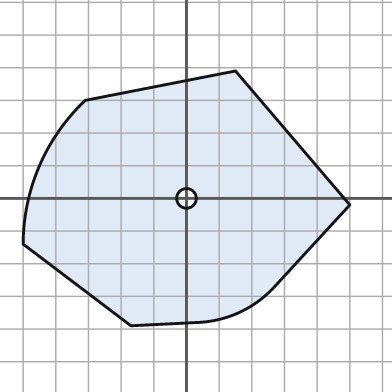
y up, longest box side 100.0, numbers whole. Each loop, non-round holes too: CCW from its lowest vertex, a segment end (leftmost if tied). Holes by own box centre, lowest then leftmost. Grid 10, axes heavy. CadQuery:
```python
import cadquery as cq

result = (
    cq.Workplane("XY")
    .moveTo(-17.0, -39.0)
    .lineTo(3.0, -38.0)
    .threePointArc((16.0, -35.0), (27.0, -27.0))
    .lineTo(50.0, -2.0)
    .lineTo(15.0, 39.0)
    .lineTo(-31.0, 30.0)
    .threePointArc((-45.0, 10.0), (-50.0, -14.0))
    .close()
    .moveTo(0.0, 0.0)
    .circle(3.0)
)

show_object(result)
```